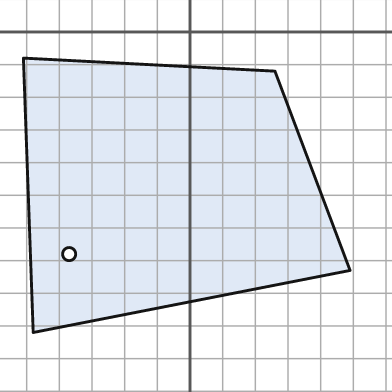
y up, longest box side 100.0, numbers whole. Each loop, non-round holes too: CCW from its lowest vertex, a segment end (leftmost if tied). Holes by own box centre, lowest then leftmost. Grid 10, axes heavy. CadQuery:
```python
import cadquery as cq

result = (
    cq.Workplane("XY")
    .moveTo(-48.0, -92.0)
    .lineTo(49.0, -73.0)
    .lineTo(26.0, -12.0)
    .lineTo(-51.0, -8.0)
    .close()
    .moveTo(-37.0, -68.0)
    .circle(2.0)
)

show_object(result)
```